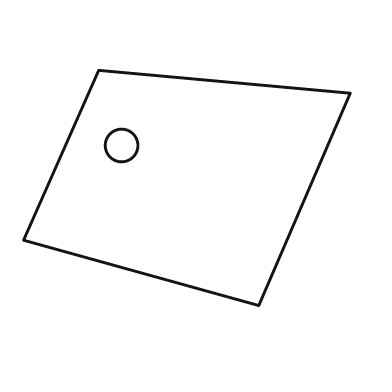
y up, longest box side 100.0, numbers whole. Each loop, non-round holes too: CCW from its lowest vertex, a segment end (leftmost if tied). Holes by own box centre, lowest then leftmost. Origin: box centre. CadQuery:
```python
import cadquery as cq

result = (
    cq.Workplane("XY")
    .moveTo(22.0, -36.0)
    .lineTo(50.0, 29.0)
    .lineTo(-27.0, 36.0)
    .lineTo(-50.0, -16.0)
    .close()
    .moveTo(-20.0, 13.0)
    .circle(5.0)
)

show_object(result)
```